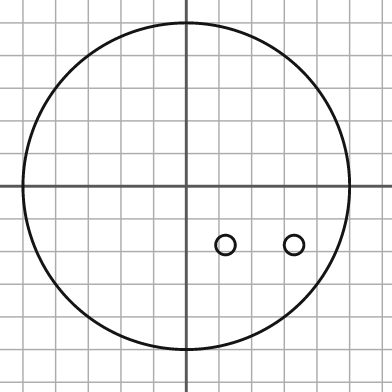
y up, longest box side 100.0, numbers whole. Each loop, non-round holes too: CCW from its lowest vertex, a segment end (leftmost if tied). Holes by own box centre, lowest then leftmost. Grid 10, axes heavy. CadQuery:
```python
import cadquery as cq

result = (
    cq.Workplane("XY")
    .moveTo(0.0, 0.0)
    .circle(50.0)
    .moveTo(12.0, -18.0)
    .circle(3.0)
    .moveTo(33.0, -18.0)
    .circle(3.0)
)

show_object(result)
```